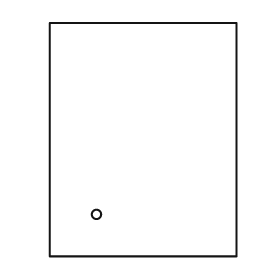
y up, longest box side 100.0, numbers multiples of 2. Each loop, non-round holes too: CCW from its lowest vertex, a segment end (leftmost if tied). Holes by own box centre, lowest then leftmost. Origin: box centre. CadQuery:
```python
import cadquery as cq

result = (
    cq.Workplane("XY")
    .moveTo(-40.0, -50.0)
    .lineTo(40.0, -50.0)
    .lineTo(40.0, 50.0)
    .lineTo(-40.0, 50.0)
    .close()
    .moveTo(-20.0, -32.0)
    .circle(2.0)
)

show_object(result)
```